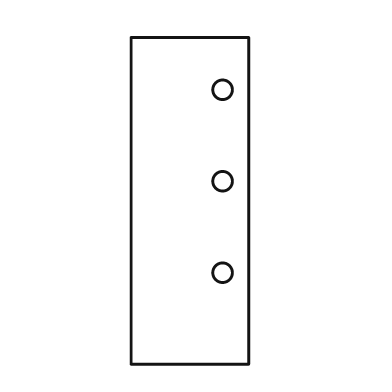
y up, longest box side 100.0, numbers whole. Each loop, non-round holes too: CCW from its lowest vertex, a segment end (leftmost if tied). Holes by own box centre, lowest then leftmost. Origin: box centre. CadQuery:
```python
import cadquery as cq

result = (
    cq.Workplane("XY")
    .moveTo(-18.0, -50.0)
    .lineTo(18.0, -50.0)
    .lineTo(18.0, 50.0)
    .lineTo(-18.0, 50.0)
    .close()
    .moveTo(10.0, -22.0)
    .circle(3.0)
    .moveTo(10.0, 6.0)
    .circle(3.0)
    .moveTo(10.0, 34.0)
    .circle(3.0)
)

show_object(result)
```